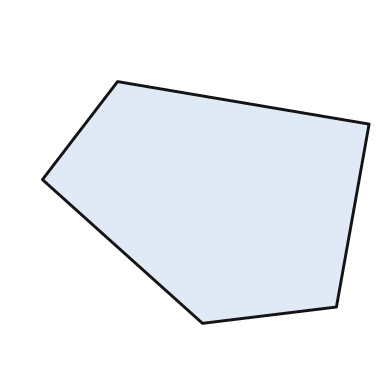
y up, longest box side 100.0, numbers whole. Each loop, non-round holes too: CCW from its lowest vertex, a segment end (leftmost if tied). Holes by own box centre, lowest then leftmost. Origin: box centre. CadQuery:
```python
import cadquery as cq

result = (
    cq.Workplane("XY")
    .moveTo(-1.0, -37.0)
    .lineTo(40.0, -32.0)
    .lineTo(50.0, 24.0)
    .lineTo(-27.0, 37.0)
    .lineTo(-50.0, 7.0)
    .close()
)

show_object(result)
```